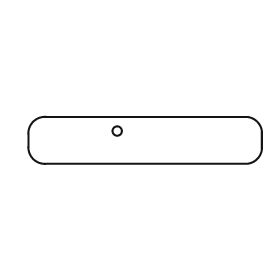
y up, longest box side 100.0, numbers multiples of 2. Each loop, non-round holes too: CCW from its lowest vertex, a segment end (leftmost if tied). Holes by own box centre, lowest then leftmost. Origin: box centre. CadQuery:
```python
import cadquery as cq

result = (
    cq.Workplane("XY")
    .moveTo(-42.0, -10.0)
    .lineTo(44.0, -10.0)
    .threePointArc((48.0, -8.0), (50.0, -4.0))
    .lineTo(50.0, 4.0)
    .threePointArc((48.0, 8.0), (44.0, 10.0))
    .lineTo(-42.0, 10.0)
    .threePointArc((-48.0, 8.0), (-50.0, 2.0))
    .lineTo(-50.0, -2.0)
    .threePointArc((-48.0, -8.0), (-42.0, -10.0))
    .close()
    .moveTo(-12.0, 4.0)
    .circle(2.0)
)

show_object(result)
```